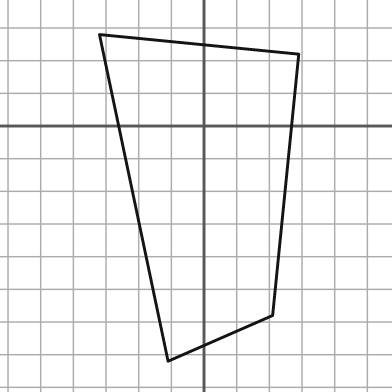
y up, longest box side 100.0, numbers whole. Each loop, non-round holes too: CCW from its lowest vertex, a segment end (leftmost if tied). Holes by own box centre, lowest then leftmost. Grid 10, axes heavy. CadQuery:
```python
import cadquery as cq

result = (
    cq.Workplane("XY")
    .moveTo(-11.0, -72.0)
    .lineTo(21.0, -58.0)
    .lineTo(29.0, 22.0)
    .lineTo(-32.0, 28.0)
    .close()
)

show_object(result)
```